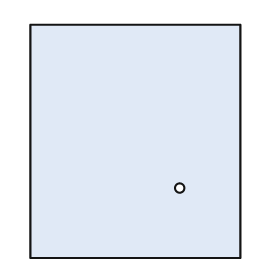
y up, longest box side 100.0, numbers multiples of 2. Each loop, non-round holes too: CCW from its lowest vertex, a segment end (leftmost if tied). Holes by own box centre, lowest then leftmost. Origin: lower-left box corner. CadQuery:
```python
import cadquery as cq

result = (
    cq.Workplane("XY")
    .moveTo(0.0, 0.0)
    .lineTo(90.0, 0.0)
    .lineTo(90.0, 100.0)
    .lineTo(0.0, 100.0)
    .close()
    .moveTo(64.0, 30.0)
    .circle(2.0)
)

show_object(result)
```